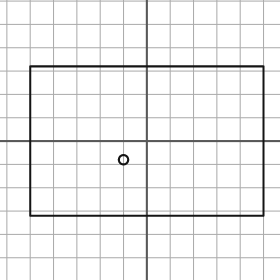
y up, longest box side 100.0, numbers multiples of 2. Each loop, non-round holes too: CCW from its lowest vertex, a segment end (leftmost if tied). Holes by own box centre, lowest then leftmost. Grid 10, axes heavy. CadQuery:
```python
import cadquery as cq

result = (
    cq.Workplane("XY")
    .moveTo(-50.0, -32.0)
    .lineTo(50.0, -32.0)
    .lineTo(50.0, 32.0)
    .lineTo(-50.0, 32.0)
    .close()
    .moveTo(-10.0, -8.0)
    .circle(2.0)
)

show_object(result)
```